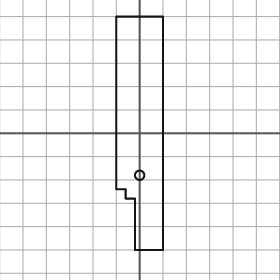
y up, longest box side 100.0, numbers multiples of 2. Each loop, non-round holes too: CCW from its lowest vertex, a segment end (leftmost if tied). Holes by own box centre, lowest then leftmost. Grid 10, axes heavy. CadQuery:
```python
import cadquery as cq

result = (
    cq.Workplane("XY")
    .moveTo(-2.0, -50.0)
    .lineTo(10.0, -50.0)
    .lineTo(10.0, 50.0)
    .lineTo(-10.0, 50.0)
    .lineTo(-10.0, -24.0)
    .lineTo(-6.0, -24.0)
    .lineTo(-6.0, -28.0)
    .lineTo(-2.0, -28.0)
    .close()
    .moveTo(0.0, -18.0)
    .circle(2.0)
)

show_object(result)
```